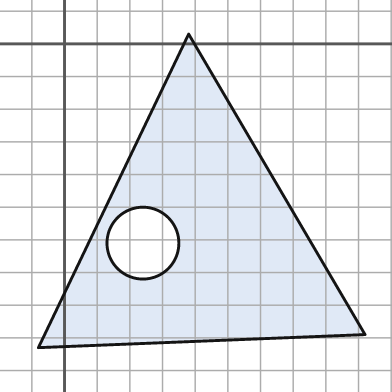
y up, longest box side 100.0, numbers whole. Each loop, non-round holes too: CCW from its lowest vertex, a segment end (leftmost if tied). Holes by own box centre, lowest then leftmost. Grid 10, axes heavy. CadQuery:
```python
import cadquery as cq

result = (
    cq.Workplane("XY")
    .moveTo(-8.0, -93.0)
    .lineTo(92.0, -89.0)
    .lineTo(38.0, 3.0)
    .close()
    .moveTo(24.0, -61.0)
    .circle(11.0)
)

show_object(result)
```